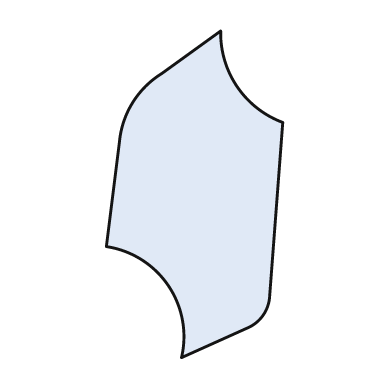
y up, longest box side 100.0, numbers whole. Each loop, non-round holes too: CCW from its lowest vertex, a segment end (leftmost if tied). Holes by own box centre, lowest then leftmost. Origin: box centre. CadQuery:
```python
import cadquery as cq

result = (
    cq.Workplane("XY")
    .moveTo(-4.0, -50.0)
    .lineTo(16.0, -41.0)
    .threePointArc((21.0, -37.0), (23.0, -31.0))
    .lineTo(27.0, 22.0)
    .threePointArc((13.0, 33.0), (8.0, 50.0))
    .lineTo(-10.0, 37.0)
    .threePointArc((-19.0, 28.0), (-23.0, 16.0))
    .lineTo(-27.0, -16.0)
    .threePointArc((-8.0, -28.0), (-4.0, -50.0))
    .close()
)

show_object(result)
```